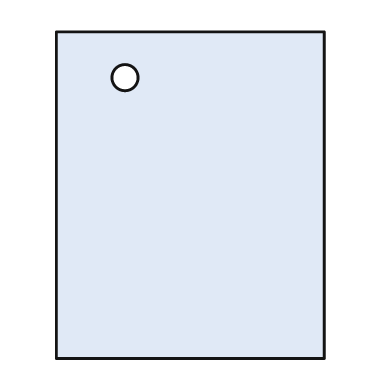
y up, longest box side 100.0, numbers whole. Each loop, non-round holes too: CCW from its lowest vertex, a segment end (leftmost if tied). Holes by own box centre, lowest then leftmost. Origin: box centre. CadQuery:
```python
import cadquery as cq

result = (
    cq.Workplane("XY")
    .moveTo(-41.0, -50.0)
    .lineTo(41.0, -50.0)
    .lineTo(41.0, 50.0)
    .lineTo(-41.0, 50.0)
    .close()
    .moveTo(-20.0, 36.0)
    .circle(4.0)
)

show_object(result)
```